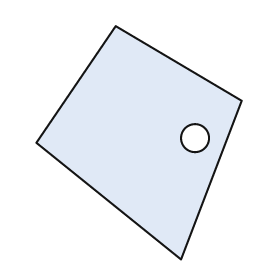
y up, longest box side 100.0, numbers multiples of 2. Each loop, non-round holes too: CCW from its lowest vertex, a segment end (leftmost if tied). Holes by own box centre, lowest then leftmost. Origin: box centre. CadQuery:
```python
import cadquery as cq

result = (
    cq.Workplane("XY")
    .moveTo(18.0, -50.0)
    .lineTo(44.0, 18.0)
    .lineTo(-10.0, 50.0)
    .lineTo(-44.0, 0.0)
    .close()
    .moveTo(24.0, 2.0)
    .circle(6.0)
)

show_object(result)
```